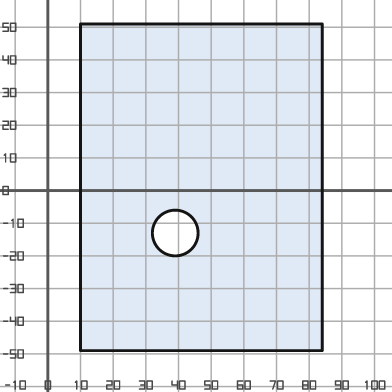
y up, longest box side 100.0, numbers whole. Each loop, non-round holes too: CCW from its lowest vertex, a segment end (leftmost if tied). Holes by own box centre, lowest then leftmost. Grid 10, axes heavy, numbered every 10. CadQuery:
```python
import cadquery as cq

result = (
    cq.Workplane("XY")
    .moveTo(10.0, -49.0)
    .lineTo(84.0, -49.0)
    .lineTo(84.0, 51.0)
    .lineTo(10.0, 51.0)
    .close()
    .moveTo(39.0, -13.0)
    .circle(7.0)
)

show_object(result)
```